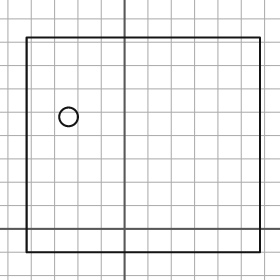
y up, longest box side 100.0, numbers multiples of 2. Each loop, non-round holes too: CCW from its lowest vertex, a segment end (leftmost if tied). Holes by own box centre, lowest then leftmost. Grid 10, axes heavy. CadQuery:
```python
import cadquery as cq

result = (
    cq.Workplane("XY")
    .moveTo(-42.0, -10.0)
    .lineTo(58.0, -10.0)
    .lineTo(58.0, 82.0)
    .lineTo(-42.0, 82.0)
    .close()
    .moveTo(-24.0, 48.0)
    .circle(4.0)
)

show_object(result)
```